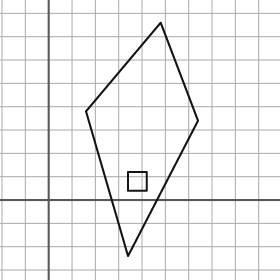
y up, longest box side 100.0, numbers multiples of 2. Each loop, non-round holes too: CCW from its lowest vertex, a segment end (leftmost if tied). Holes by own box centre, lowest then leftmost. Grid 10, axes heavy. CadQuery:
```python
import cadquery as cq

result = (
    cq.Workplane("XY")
    .moveTo(34.0, -24.0)
    .lineTo(64.0, 34.0)
    .lineTo(48.0, 76.0)
    .lineTo(16.0, 38.0)
    .close()
    .moveTo(34.0, 4.0)
    .lineTo(42.0, 4.0)
    .lineTo(42.0, 12.0)
    .lineTo(34.0, 12.0)
    .close()
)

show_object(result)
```